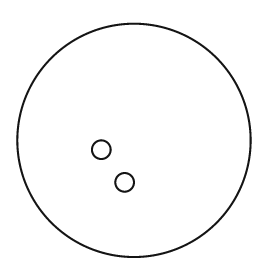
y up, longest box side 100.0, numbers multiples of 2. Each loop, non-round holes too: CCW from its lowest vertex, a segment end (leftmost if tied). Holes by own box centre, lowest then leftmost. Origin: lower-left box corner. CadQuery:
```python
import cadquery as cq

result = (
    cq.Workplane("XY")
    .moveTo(50.0, 50.0)
    .circle(50.0)
    .moveTo(46.0, 32.0)
    .circle(4.0)
    .moveTo(36.0, 46.0)
    .circle(4.0)
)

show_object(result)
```